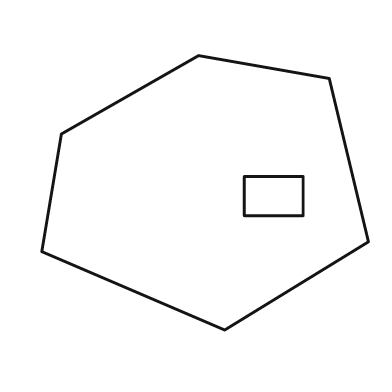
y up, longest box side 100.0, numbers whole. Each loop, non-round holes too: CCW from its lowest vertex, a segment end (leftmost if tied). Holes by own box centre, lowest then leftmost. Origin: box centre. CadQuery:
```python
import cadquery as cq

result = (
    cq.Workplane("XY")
    .moveTo(6.0, -42.0)
    .lineTo(50.0, -15.0)
    .lineTo(38.0, 35.0)
    .lineTo(-2.0, 42.0)
    .lineTo(-44.0, 18.0)
    .lineTo(-50.0, -18.0)
    .close()
    .moveTo(12.0, -7.0)
    .lineTo(30.0, -7.0)
    .lineTo(30.0, 5.0)
    .lineTo(12.0, 5.0)
    .close()
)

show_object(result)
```